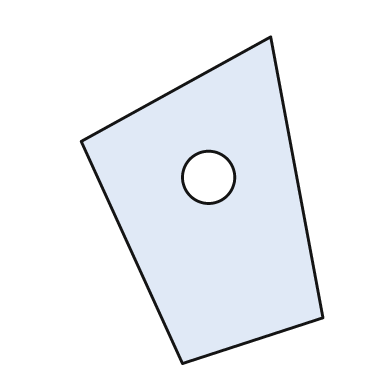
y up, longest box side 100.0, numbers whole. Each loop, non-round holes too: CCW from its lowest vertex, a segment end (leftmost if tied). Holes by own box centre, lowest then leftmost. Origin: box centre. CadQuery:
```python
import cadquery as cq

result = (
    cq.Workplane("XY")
    .moveTo(-6.0, -50.0)
    .lineTo(37.0, -36.0)
    .lineTo(21.0, 50.0)
    .lineTo(-37.0, 18.0)
    .close()
    .moveTo(2.0, 7.0)
    .circle(8.0)
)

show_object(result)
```